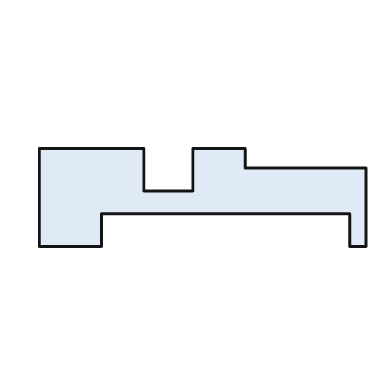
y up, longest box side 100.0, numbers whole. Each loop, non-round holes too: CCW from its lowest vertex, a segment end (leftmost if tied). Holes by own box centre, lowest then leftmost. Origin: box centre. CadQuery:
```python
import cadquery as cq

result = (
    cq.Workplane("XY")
    .moveTo(-50.0, -15.0)
    .lineTo(-31.0, -15.0)
    .lineTo(-31.0, -5.0)
    .lineTo(45.0, -5.0)
    .lineTo(45.0, -15.0)
    .lineTo(50.0, -15.0)
    .lineTo(50.0, 9.0)
    .lineTo(13.0, 9.0)
    .lineTo(13.0, 15.0)
    .lineTo(-3.0, 15.0)
    .lineTo(-3.0, 2.0)
    .lineTo(-18.0, 2.0)
    .lineTo(-18.0, 15.0)
    .lineTo(-50.0, 15.0)
    .close()
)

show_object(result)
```